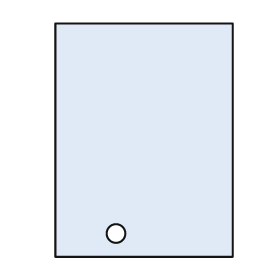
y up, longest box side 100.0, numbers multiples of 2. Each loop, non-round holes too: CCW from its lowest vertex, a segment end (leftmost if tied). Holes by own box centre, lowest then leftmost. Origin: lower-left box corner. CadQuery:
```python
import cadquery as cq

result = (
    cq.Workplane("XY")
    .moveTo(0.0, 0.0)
    .lineTo(76.0, 0.0)
    .lineTo(76.0, 100.0)
    .lineTo(0.0, 100.0)
    .close()
    .moveTo(26.0, 10.0)
    .circle(4.0)
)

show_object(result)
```